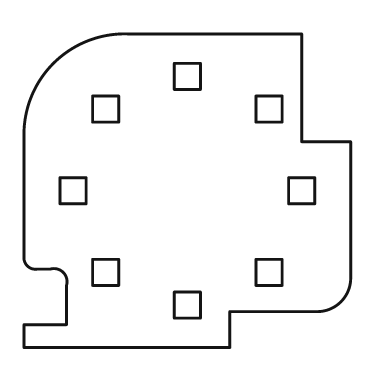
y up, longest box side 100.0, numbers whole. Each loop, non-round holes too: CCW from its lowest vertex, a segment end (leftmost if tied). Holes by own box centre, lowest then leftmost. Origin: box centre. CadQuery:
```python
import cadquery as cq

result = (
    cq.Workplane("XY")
    .moveTo(-50.0, -48.0)
    .lineTo(13.0, -48.0)
    .lineTo(13.0, -37.0)
    .lineTo(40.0, -37.0)
    .threePointArc((47.0, -34.0), (50.0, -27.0))
    .lineTo(50.0, 15.0)
    .lineTo(35.0, 15.0)
    .lineTo(35.0, 48.0)
    .lineTo(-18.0, 48.0)
    .threePointArc((-41.0, 39.0), (-50.0, 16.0))
    .lineTo(-50.0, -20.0)
    .threePointArc((-49.0, -23.0), (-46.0, -24.0))
    .lineTo(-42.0, -24.0)
    .threePointArc((-38.0, -25.0), (-37.0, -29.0))
    .lineTo(-37.0, -41.0)
    .lineTo(-50.0, -41.0)
    .close()
    .moveTo(-4.0, -39.0)
    .lineTo(4.0, -39.0)
    .lineTo(4.0, -31.0)
    .lineTo(-4.0, -31.0)
    .close()
    .moveTo(-29.0, -29.0)
    .lineTo(-21.0, -29.0)
    .lineTo(-21.0, -21.0)
    .lineTo(-29.0, -21.0)
    .close()
    .moveTo(21.0, -29.0)
    .lineTo(29.0, -29.0)
    .lineTo(29.0, -21.0)
    .lineTo(21.0, -21.0)
    .close()
    .moveTo(-39.0, -4.0)
    .lineTo(-31.0, -4.0)
    .lineTo(-31.0, 4.0)
    .lineTo(-39.0, 4.0)
    .close()
    .moveTo(31.0, -4.0)
    .lineTo(39.0, -4.0)
    .lineTo(39.0, 4.0)
    .lineTo(31.0, 4.0)
    .close()
    .moveTo(-29.0, 21.0)
    .lineTo(-21.0, 21.0)
    .lineTo(-21.0, 29.0)
    .lineTo(-29.0, 29.0)
    .close()
    .moveTo(21.0, 21.0)
    .lineTo(29.0, 21.0)
    .lineTo(29.0, 29.0)
    .lineTo(21.0, 29.0)
    .close()
    .moveTo(-4.0, 31.0)
    .lineTo(4.0, 31.0)
    .lineTo(4.0, 39.0)
    .lineTo(-4.0, 39.0)
    .close()
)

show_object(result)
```